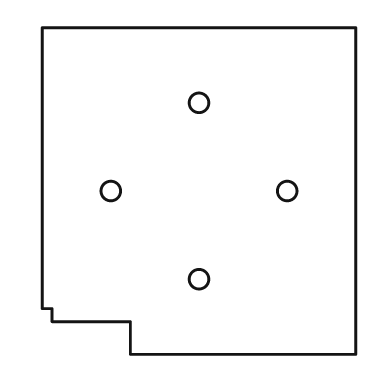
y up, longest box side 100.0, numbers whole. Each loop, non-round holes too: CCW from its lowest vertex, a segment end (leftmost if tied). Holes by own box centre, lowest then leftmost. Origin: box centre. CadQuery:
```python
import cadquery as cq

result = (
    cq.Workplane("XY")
    .moveTo(-21.0, -50.0)
    .lineTo(48.0, -50.0)
    .lineTo(48.0, 50.0)
    .lineTo(-48.0, 50.0)
    .lineTo(-48.0, -36.0)
    .lineTo(-45.0, -36.0)
    .lineTo(-45.0, -40.0)
    .lineTo(-21.0, -40.0)
    .close()
    .moveTo(0.0, -27.0)
    .circle(3.0)
    .moveTo(-27.0, 0.0)
    .circle(3.0)
    .moveTo(27.0, 0.0)
    .circle(3.0)
    .moveTo(0.0, 27.0)
    .circle(3.0)
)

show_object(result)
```